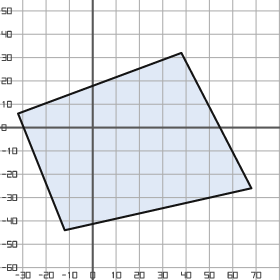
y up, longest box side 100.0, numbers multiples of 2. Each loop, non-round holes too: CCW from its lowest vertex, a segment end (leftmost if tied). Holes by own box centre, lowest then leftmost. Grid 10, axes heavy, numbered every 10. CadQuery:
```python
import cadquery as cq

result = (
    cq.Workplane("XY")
    .moveTo(-12.0, -44.0)
    .lineTo(68.0, -26.0)
    .lineTo(38.0, 32.0)
    .lineTo(-32.0, 6.0)
    .close()
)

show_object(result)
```